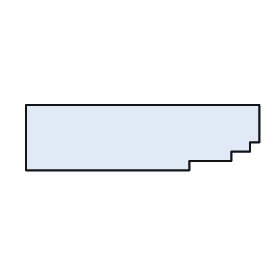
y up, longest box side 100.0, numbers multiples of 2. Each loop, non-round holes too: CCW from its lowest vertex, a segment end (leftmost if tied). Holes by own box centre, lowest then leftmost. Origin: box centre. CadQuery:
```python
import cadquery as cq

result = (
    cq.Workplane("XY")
    .moveTo(-50.0, -14.0)
    .lineTo(20.0, -14.0)
    .lineTo(20.0, -10.0)
    .lineTo(38.0, -10.0)
    .lineTo(38.0, -6.0)
    .lineTo(46.0, -6.0)
    .lineTo(46.0, -2.0)
    .lineTo(50.0, -2.0)
    .lineTo(50.0, 14.0)
    .lineTo(-50.0, 14.0)
    .close()
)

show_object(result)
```